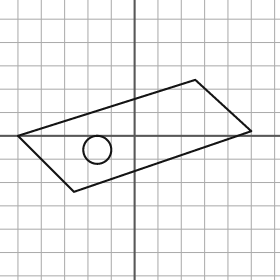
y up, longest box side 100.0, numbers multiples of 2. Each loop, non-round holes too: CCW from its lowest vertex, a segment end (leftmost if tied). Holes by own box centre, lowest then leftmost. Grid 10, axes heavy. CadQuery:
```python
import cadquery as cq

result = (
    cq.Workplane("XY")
    .moveTo(-26.0, -24.0)
    .lineTo(50.0, 2.0)
    .lineTo(26.0, 24.0)
    .lineTo(-50.0, 0.0)
    .close()
    .moveTo(-16.0, -6.0)
    .circle(6.0)
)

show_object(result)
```